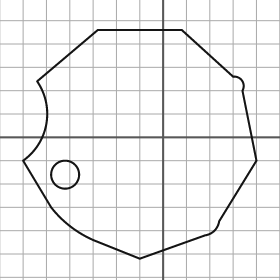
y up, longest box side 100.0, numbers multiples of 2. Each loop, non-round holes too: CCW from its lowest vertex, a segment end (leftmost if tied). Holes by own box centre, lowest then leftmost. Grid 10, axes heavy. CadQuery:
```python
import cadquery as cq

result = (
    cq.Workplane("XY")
    .moveTo(-10.0, -52.0)
    .lineTo(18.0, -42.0)
    .threePointArc((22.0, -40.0), (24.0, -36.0))
    .lineTo(40.0, -10.0)
    .lineTo(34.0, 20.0)
    .threePointArc((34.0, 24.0), (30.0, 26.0))
    .lineTo(8.0, 46.0)
    .lineTo(-28.0, 46.0)
    .lineTo(-54.0, 24.0)
    .threePointArc((-50.0, 6.0), (-60.0, -10.0))
    .lineTo(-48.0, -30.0)
    .threePointArc((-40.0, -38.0), (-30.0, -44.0))
    .close()
    .moveTo(-42.0, -16.0)
    .circle(6.0)
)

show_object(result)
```